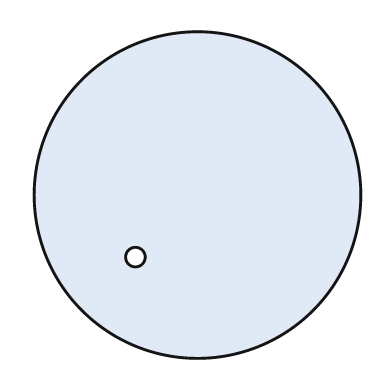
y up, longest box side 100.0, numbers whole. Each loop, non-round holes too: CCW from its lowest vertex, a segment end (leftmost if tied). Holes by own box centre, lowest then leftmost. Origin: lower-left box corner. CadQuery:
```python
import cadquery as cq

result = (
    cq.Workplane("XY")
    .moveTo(50.0, 50.0)
    .circle(50.0)
    .moveTo(31.0, 31.0)
    .circle(3.0)
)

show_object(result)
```